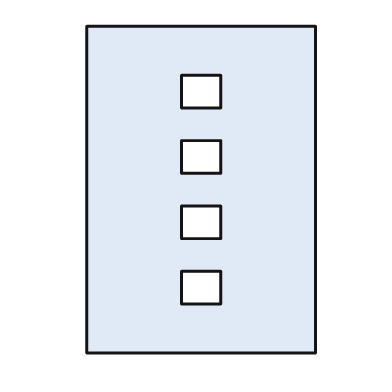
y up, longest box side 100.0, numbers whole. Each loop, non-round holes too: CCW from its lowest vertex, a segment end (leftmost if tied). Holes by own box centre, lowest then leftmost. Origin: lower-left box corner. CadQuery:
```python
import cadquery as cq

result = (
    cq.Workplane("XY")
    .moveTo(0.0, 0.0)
    .lineTo(70.0, 0.0)
    .lineTo(70.0, 100.0)
    .lineTo(0.0, 100.0)
    .close()
    .moveTo(29.0, 15.0)
    .lineTo(41.0, 15.0)
    .lineTo(41.0, 25.0)
    .lineTo(29.0, 25.0)
    .close()
    .moveTo(29.0, 35.0)
    .lineTo(41.0, 35.0)
    .lineTo(41.0, 45.0)
    .lineTo(29.0, 45.0)
    .close()
    .moveTo(29.0, 55.0)
    .lineTo(41.0, 55.0)
    .lineTo(41.0, 65.0)
    .lineTo(29.0, 65.0)
    .close()
    .moveTo(29.0, 75.0)
    .lineTo(41.0, 75.0)
    .lineTo(41.0, 85.0)
    .lineTo(29.0, 85.0)
    .close()
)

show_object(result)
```